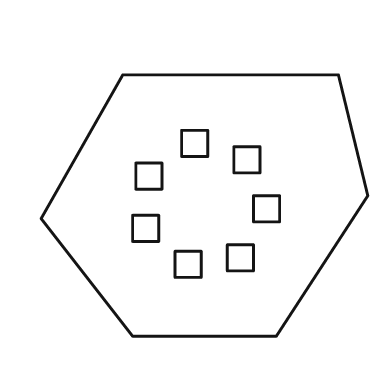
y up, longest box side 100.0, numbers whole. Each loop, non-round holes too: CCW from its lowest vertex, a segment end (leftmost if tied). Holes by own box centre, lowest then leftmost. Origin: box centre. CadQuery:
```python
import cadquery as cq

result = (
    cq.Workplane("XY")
    .moveTo(-22.0, -40.0)
    .lineTo(22.0, -40.0)
    .lineTo(50.0, 3.0)
    .lineTo(41.0, 40.0)
    .lineTo(-25.0, 40.0)
    .lineTo(-50.0, -4.0)
    .close()
    .moveTo(-9.0, -22.0)
    .lineTo(-1.0, -22.0)
    .lineTo(-1.0, -14.0)
    .lineTo(-9.0, -14.0)
    .close()
    .moveTo(7.0, -20.0)
    .lineTo(15.0, -20.0)
    .lineTo(15.0, -12.0)
    .lineTo(7.0, -12.0)
    .close()
    .moveTo(-22.0, -11.0)
    .lineTo(-14.0, -11.0)
    .lineTo(-14.0, -3.0)
    .lineTo(-22.0, -3.0)
    .close()
    .moveTo(15.0, -5.0)
    .lineTo(23.0, -5.0)
    .lineTo(23.0, 3.0)
    .lineTo(15.0, 3.0)
    .close()
    .moveTo(-21.0, 5.0)
    .lineTo(-13.0, 5.0)
    .lineTo(-13.0, 13.0)
    .lineTo(-21.0, 13.0)
    .close()
    .moveTo(9.0, 10.0)
    .lineTo(17.0, 10.0)
    .lineTo(17.0, 18.0)
    .lineTo(9.0, 18.0)
    .close()
    .moveTo(-7.0, 15.0)
    .lineTo(1.0, 15.0)
    .lineTo(1.0, 23.0)
    .lineTo(-7.0, 23.0)
    .close()
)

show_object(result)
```